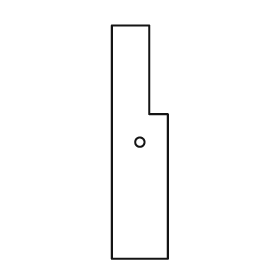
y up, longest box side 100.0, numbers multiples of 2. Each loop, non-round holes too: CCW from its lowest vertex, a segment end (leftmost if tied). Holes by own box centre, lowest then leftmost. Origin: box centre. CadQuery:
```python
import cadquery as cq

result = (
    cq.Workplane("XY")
    .moveTo(-12.0, -50.0)
    .lineTo(12.0, -50.0)
    .lineTo(12.0, 12.0)
    .lineTo(4.0, 12.0)
    .lineTo(4.0, 50.0)
    .lineTo(-12.0, 50.0)
    .close()
    .moveTo(0.0, 0.0)
    .circle(2.0)
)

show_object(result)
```